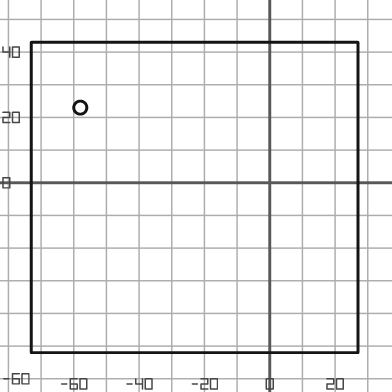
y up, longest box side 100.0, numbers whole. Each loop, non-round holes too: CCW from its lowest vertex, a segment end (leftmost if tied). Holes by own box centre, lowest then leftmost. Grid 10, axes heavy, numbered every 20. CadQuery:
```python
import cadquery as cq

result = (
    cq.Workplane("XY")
    .moveTo(-73.0, -52.0)
    .lineTo(27.0, -52.0)
    .lineTo(27.0, 43.0)
    .lineTo(-73.0, 43.0)
    .close()
    .moveTo(-58.0, 23.0)
    .circle(2.0)
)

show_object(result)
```